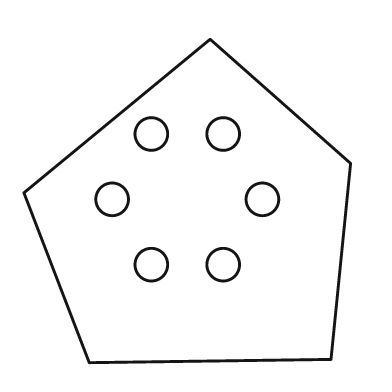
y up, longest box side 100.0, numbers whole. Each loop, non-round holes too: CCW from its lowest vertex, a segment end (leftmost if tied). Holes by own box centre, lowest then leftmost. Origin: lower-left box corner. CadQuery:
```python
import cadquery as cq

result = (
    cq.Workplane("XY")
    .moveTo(20.0, 0.0)
    .lineTo(94.0, 1.0)
    .lineTo(100.0, 61.0)
    .lineTo(57.0, 99.0)
    .lineTo(0.0, 52.0)
    .close()
    .moveTo(39.0, 30.0)
    .circle(5.0)
    .moveTo(61.0, 30.0)
    .circle(5.0)
    .moveTo(27.0, 50.0)
    .circle(5.0)
    .moveTo(73.0, 50.0)
    .circle(5.0)
    .moveTo(39.0, 70.0)
    .circle(5.0)
    .moveTo(61.0, 70.0)
    .circle(5.0)
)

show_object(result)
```